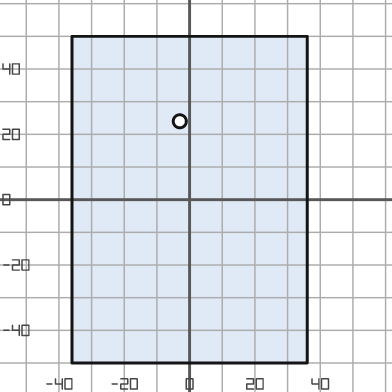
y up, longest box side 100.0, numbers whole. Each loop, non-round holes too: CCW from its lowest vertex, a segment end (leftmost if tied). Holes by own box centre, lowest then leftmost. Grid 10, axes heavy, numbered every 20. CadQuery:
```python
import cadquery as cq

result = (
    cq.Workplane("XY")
    .moveTo(-36.0, -50.0)
    .lineTo(36.0, -50.0)
    .lineTo(36.0, 50.0)
    .lineTo(-36.0, 50.0)
    .close()
    .moveTo(-3.0, 24.0)
    .circle(2.0)
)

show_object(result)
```